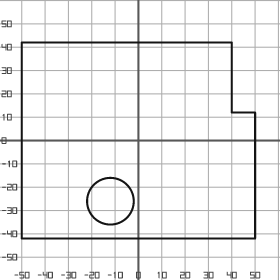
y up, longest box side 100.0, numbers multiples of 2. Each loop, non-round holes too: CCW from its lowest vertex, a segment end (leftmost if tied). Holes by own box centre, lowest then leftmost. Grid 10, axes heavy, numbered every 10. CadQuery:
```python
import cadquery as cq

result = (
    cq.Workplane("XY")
    .moveTo(-50.0, -42.0)
    .lineTo(50.0, -42.0)
    .lineTo(50.0, 12.0)
    .lineTo(40.0, 12.0)
    .lineTo(40.0, 42.0)
    .lineTo(-50.0, 42.0)
    .close()
    .moveTo(-12.0, -26.0)
    .circle(10.0)
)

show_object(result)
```